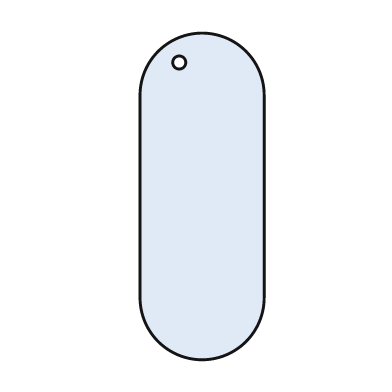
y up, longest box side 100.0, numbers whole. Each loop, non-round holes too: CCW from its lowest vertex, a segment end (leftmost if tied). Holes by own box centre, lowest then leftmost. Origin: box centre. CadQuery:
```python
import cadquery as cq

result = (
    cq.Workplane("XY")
    .moveTo(-19.0, -31.0)
    .threePointArc((0.0, -50.0), (19.0, -31.0))
    .lineTo(19.0, 31.0)
    .threePointArc((0.0, 50.0), (-19.0, 31.0))
    .close()
    .moveTo(-7.0, 41.0)
    .circle(2.0)
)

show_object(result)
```